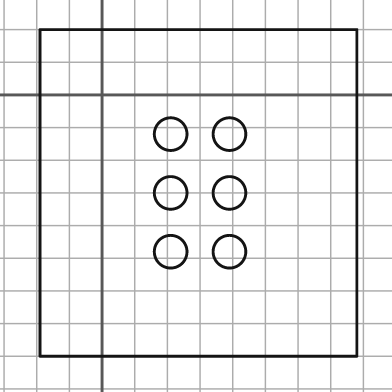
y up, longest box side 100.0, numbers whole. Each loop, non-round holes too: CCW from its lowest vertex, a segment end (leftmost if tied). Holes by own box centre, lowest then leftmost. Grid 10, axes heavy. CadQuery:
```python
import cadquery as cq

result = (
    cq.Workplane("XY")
    .moveTo(-19.0, -80.0)
    .lineTo(78.0, -80.0)
    .lineTo(78.0, 20.0)
    .lineTo(-19.0, 20.0)
    .close()
    .moveTo(21.0, -48.0)
    .circle(5.0)
    .moveTo(39.0, -48.0)
    .circle(5.0)
    .moveTo(21.0, -30.0)
    .circle(5.0)
    .moveTo(39.0, -30.0)
    .circle(5.0)
    .moveTo(21.0, -12.0)
    .circle(5.0)
    .moveTo(39.0, -12.0)
    .circle(5.0)
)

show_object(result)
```